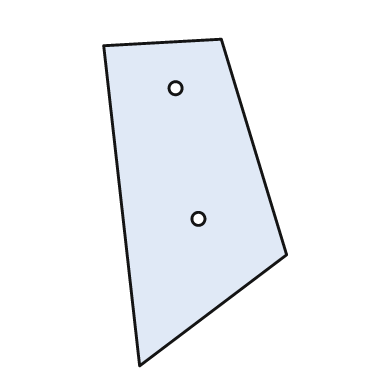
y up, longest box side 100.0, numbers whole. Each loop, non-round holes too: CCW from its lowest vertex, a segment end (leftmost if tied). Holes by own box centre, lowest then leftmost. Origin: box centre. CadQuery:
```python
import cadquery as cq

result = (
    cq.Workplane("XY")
    .moveTo(-17.0, -50.0)
    .lineTo(28.0, -16.0)
    .lineTo(8.0, 50.0)
    .lineTo(-28.0, 48.0)
    .close()
    .moveTo(1.0, -5.0)
    .circle(2.0)
    .moveTo(-6.0, 35.0)
    .circle(2.0)
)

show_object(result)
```